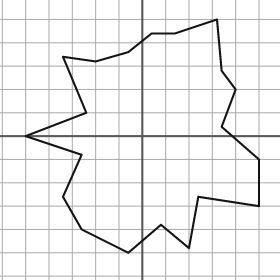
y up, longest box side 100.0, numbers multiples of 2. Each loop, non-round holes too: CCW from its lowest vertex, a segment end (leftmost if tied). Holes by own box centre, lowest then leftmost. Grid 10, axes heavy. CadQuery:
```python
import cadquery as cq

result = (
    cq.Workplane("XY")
    .moveTo(-6.0, -50.0)
    .lineTo(8.0, -38.0)
    .lineTo(20.0, -48.0)
    .lineTo(24.0, -26.0)
    .lineTo(50.0, -30.0)
    .lineTo(50.0, -10.0)
    .lineTo(34.0, 4.0)
    .lineTo(40.0, 20.0)
    .lineTo(34.0, 28.0)
    .lineTo(32.0, 50.0)
    .lineTo(14.0, 44.0)
    .lineTo(4.0, 44.0)
    .lineTo(-6.0, 36.0)
    .lineTo(-20.0, 32.0)
    .lineTo(-34.0, 34.0)
    .lineTo(-24.0, 10.0)
    .lineTo(-50.0, 0.0)
    .lineTo(-26.0, -8.0)
    .lineTo(-34.0, -26.0)
    .lineTo(-26.0, -40.0)
    .close()
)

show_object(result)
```